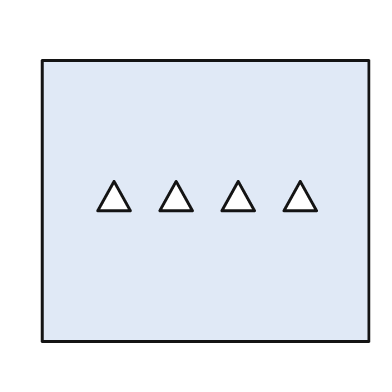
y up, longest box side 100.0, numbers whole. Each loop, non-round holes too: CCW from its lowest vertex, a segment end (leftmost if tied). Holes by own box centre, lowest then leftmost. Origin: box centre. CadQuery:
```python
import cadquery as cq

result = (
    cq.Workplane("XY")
    .moveTo(-50.0, -43.0)
    .lineTo(50.0, -43.0)
    .lineTo(50.0, 43.0)
    .lineTo(-50.0, 43.0)
    .close()
    .moveTo(-33.0, -3.0)
    .lineTo(-23.0, -3.0)
    .lineTo(-28.0, 6.0)
    .close()
    .moveTo(-14.0, -3.0)
    .lineTo(-4.0, -3.0)
    .lineTo(-9.0, 6.0)
    .close()
    .moveTo(5.0, -3.0)
    .lineTo(15.0, -3.0)
    .lineTo(10.0, 6.0)
    .close()
    .moveTo(24.0, -3.0)
    .lineTo(34.0, -3.0)
    .lineTo(29.0, 6.0)
    .close()
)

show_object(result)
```